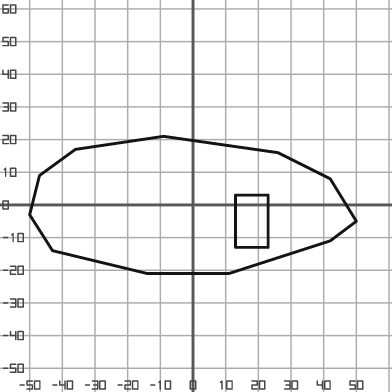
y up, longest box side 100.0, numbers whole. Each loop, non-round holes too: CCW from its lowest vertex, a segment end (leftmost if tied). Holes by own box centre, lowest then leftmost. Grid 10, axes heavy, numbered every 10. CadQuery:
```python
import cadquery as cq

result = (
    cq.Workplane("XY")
    .moveTo(-14.0, -21.0)
    .lineTo(11.0, -21.0)
    .lineTo(42.0, -11.0)
    .lineTo(50.0, -5.0)
    .lineTo(42.0, 8.0)
    .lineTo(26.0, 16.0)
    .lineTo(-9.0, 21.0)
    .lineTo(-36.0, 17.0)
    .lineTo(-47.0, 9.0)
    .lineTo(-50.0, -3.0)
    .lineTo(-43.0, -14.0)
    .close()
    .moveTo(13.0, -13.0)
    .lineTo(23.0, -13.0)
    .lineTo(23.0, 3.0)
    .lineTo(13.0, 3.0)
    .close()
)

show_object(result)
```